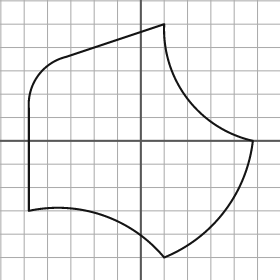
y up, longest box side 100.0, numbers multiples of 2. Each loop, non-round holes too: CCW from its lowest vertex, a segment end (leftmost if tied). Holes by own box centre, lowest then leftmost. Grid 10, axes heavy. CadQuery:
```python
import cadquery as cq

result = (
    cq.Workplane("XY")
    .moveTo(10.0, -50.0)
    .threePointArc((36.0, -30.0), (48.0, 0.0))
    .threePointArc((20.0, 18.0), (10.0, 50.0))
    .lineTo(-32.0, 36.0)
    .threePointArc((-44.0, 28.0), (-48.0, 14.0))
    .lineTo(-48.0, -30.0)
    .threePointArc((-16.0, -32.0), (10.0, -50.0))
    .close()
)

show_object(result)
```